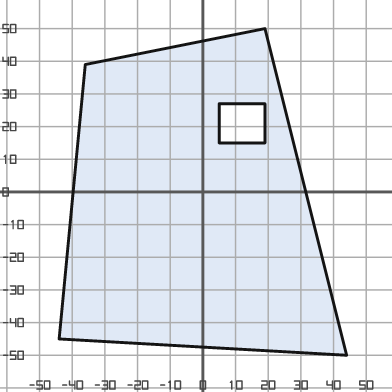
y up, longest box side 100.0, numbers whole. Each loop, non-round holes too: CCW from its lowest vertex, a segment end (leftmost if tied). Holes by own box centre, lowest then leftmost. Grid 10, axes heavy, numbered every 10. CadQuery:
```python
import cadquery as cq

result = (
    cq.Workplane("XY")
    .moveTo(44.0, -50.0)
    .lineTo(19.0, 50.0)
    .lineTo(-36.0, 39.0)
    .lineTo(-44.0, -45.0)
    .close()
    .moveTo(5.0, 15.0)
    .lineTo(19.0, 15.0)
    .lineTo(19.0, 27.0)
    .lineTo(5.0, 27.0)
    .close()
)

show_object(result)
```